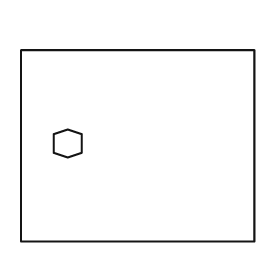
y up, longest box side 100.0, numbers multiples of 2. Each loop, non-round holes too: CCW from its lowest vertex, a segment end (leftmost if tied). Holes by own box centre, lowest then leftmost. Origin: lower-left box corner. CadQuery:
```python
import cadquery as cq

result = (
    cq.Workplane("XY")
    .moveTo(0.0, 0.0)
    .lineTo(100.0, 0.0)
    .lineTo(100.0, 82.0)
    .lineTo(0.0, 82.0)
    .close()
    .moveTo(20.0, 36.0)
    .lineTo(26.0, 38.0)
    .lineTo(26.0, 46.0)
    .lineTo(20.0, 48.0)
    .lineTo(14.0, 46.0)
    .lineTo(14.0, 38.0)
    .close()
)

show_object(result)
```